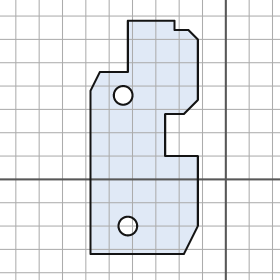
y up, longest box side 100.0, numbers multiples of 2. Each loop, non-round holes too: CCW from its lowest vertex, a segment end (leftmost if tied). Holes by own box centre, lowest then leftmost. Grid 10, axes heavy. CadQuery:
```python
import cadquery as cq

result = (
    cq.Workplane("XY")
    .moveTo(-58.0, -32.0)
    .lineTo(-18.0, -32.0)
    .lineTo(-12.0, -20.0)
    .lineTo(-12.0, 10.0)
    .lineTo(-26.0, 10.0)
    .lineTo(-26.0, 28.0)
    .lineTo(-18.0, 28.0)
    .lineTo(-12.0, 34.0)
    .lineTo(-12.0, 60.0)
    .lineTo(-16.0, 64.0)
    .lineTo(-22.0, 64.0)
    .lineTo(-22.0, 68.0)
    .lineTo(-42.0, 68.0)
    .lineTo(-42.0, 46.0)
    .lineTo(-54.0, 46.0)
    .lineTo(-58.0, 38.0)
    .close()
    .moveTo(-42.0, -20.0)
    .circle(4.0)
    .moveTo(-44.0, 36.0)
    .circle(4.0)
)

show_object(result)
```